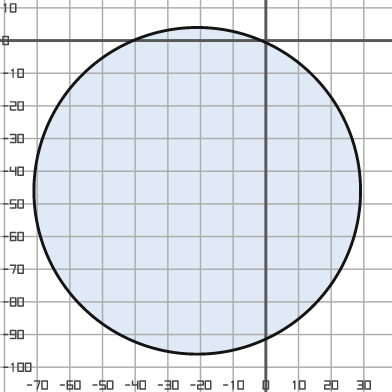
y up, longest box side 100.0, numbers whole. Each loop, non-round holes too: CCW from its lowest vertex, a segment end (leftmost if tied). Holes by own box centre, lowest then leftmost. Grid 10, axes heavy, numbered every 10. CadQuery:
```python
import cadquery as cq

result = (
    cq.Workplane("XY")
    .moveTo(-21.0, -46.0)
    .circle(50.0)
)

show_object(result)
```